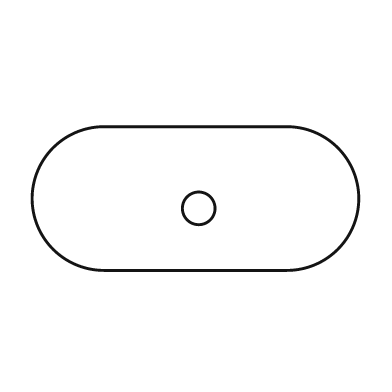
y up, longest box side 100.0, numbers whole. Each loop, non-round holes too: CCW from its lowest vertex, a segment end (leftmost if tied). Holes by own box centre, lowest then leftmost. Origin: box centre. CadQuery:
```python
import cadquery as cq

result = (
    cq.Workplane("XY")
    .moveTo(-28.0, -22.0)
    .lineTo(28.0, -22.0)
    .threePointArc((50.0, 0.0), (28.0, 22.0))
    .lineTo(-28.0, 22.0)
    .threePointArc((-50.0, 0.0), (-28.0, -22.0))
    .close()
    .moveTo(1.0, -3.0)
    .circle(5.0)
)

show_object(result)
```